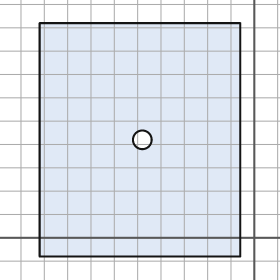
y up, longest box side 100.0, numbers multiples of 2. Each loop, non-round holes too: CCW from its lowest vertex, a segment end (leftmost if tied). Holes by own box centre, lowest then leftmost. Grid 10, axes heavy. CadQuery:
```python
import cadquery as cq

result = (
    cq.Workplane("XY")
    .moveTo(-92.0, -8.0)
    .lineTo(-6.0, -8.0)
    .lineTo(-6.0, 92.0)
    .lineTo(-92.0, 92.0)
    .close()
    .moveTo(-48.0, 42.0)
    .circle(4.0)
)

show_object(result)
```